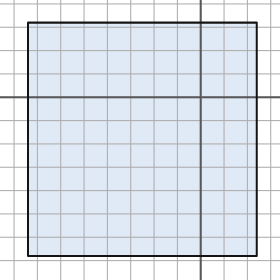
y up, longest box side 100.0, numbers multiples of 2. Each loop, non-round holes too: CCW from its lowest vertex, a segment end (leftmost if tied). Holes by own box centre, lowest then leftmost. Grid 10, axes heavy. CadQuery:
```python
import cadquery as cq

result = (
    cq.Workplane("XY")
    .moveTo(-74.0, -68.0)
    .lineTo(24.0, -68.0)
    .lineTo(24.0, 32.0)
    .lineTo(-74.0, 32.0)
    .close()
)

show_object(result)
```